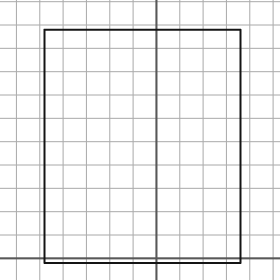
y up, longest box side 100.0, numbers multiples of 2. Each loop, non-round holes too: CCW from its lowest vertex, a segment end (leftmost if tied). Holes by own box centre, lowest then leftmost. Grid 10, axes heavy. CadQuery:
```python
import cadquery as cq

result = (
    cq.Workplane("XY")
    .moveTo(-48.0, -2.0)
    .lineTo(36.0, -2.0)
    .lineTo(36.0, 98.0)
    .lineTo(-48.0, 98.0)
    .close()
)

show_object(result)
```